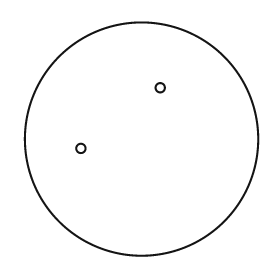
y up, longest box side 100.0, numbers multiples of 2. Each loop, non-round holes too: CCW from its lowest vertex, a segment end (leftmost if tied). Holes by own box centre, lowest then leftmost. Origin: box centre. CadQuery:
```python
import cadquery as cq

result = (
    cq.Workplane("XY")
    .moveTo(0.0, 0.0)
    .circle(50.0)
    .moveTo(-26.0, -4.0)
    .circle(2.0)
    .moveTo(8.0, 22.0)
    .circle(2.0)
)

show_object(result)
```